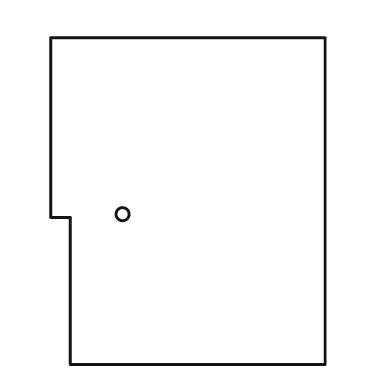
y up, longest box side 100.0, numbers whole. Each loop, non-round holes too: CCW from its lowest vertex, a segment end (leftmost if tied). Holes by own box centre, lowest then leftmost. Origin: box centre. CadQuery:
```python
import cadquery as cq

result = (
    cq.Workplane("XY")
    .moveTo(-36.0, -50.0)
    .lineTo(42.0, -50.0)
    .lineTo(42.0, 50.0)
    .lineTo(-42.0, 50.0)
    .lineTo(-42.0, -5.0)
    .lineTo(-36.0, -5.0)
    .close()
    .moveTo(-20.0, -4.0)
    .circle(2.0)
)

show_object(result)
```